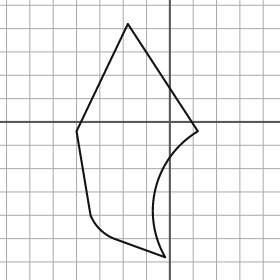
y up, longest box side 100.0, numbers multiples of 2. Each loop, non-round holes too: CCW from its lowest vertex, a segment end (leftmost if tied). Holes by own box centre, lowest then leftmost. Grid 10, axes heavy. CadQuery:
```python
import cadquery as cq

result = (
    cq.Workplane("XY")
    .moveTo(-2.0, -58.0)
    .threePointArc((-6.0, -28.0), (12.0, -4.0))
    .lineTo(-18.0, 42.0)
    .lineTo(-40.0, -4.0)
    .lineTo(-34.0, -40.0)
    .threePointArc((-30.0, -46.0), (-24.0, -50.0))
    .close()
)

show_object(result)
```